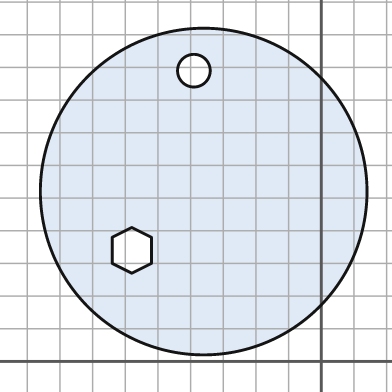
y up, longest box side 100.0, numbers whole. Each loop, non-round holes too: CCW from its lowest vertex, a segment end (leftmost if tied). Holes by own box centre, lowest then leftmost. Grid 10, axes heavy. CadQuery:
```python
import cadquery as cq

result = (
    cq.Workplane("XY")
    .moveTo(-36.0, 52.0)
    .circle(50.0)
    .moveTo(-58.0, 27.0)
    .lineTo(-52.0, 30.0)
    .lineTo(-52.0, 38.0)
    .lineTo(-58.0, 41.0)
    .lineTo(-64.0, 38.0)
    .lineTo(-64.0, 30.0)
    .close()
    .moveTo(-39.0, 89.0)
    .circle(5.0)
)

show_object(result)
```